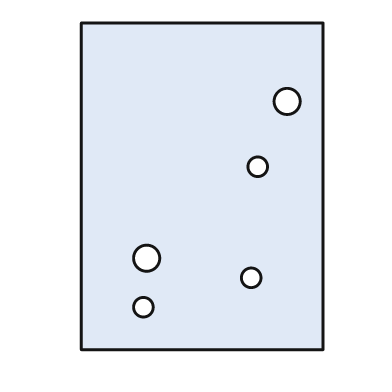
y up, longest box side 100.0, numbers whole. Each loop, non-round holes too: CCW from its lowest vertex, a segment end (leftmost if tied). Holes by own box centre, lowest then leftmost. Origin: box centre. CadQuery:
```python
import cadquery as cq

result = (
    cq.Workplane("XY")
    .moveTo(-37.0, -50.0)
    .lineTo(37.0, -50.0)
    .lineTo(37.0, 50.0)
    .lineTo(-37.0, 50.0)
    .close()
    .moveTo(-18.0, -37.0)
    .circle(3.0)
    .moveTo(15.0, -28.0)
    .circle(3.0)
    .moveTo(-17.0, -22.0)
    .circle(4.0)
    .moveTo(17.0, 6.0)
    .circle(3.0)
    .moveTo(26.0, 26.0)
    .circle(4.0)
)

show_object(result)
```